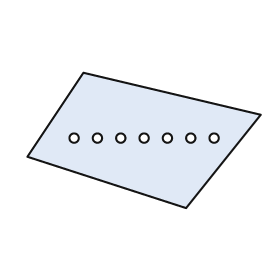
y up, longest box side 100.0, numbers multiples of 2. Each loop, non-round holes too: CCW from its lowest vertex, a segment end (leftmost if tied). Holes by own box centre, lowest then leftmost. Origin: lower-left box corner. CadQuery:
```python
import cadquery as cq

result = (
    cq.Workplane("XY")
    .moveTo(68.0, 0.0)
    .lineTo(100.0, 40.0)
    .lineTo(24.0, 58.0)
    .lineTo(0.0, 22.0)
    .close()
    .moveTo(20.0, 30.0)
    .circle(2.0)
    .moveTo(30.0, 30.0)
    .circle(2.0)
    .moveTo(40.0, 30.0)
    .circle(2.0)
    .moveTo(50.0, 30.0)
    .circle(2.0)
    .moveTo(60.0, 30.0)
    .circle(2.0)
    .moveTo(70.0, 30.0)
    .circle(2.0)
    .moveTo(80.0, 30.0)
    .circle(2.0)
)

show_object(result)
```